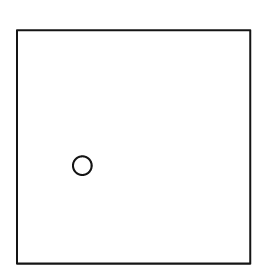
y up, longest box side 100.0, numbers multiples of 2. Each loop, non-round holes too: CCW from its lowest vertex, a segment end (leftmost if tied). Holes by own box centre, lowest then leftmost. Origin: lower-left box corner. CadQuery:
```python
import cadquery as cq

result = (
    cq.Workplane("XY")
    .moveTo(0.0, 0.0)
    .lineTo(100.0, 0.0)
    .lineTo(100.0, 100.0)
    .lineTo(0.0, 100.0)
    .close()
    .moveTo(28.0, 42.0)
    .circle(4.0)
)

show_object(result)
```